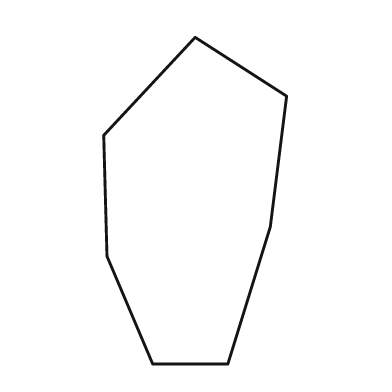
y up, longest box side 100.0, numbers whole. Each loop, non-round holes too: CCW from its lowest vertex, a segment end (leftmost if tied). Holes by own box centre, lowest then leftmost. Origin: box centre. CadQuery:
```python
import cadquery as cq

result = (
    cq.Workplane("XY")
    .moveTo(-13.0, -50.0)
    .lineTo(10.0, -50.0)
    .lineTo(23.0, -8.0)
    .lineTo(28.0, 32.0)
    .lineTo(0.0, 50.0)
    .lineTo(-28.0, 20.0)
    .lineTo(-27.0, -17.0)
    .close()
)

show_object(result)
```